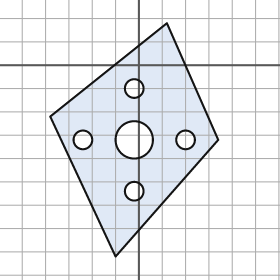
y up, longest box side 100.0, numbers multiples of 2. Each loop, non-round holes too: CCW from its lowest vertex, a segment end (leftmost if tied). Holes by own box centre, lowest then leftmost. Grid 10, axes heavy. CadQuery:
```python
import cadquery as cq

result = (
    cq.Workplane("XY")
    .moveTo(-10.0, -82.0)
    .lineTo(34.0, -32.0)
    .lineTo(12.0, 18.0)
    .lineTo(-38.0, -22.0)
    .close()
    .moveTo(-2.0, -54.0)
    .circle(4.0)
    .moveTo(-24.0, -32.0)
    .circle(4.0)
    .moveTo(-2.0, -32.0)
    .circle(8.0)
    .moveTo(20.0, -32.0)
    .circle(4.0)
    .moveTo(-2.0, -10.0)
    .circle(4.0)
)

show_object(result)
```